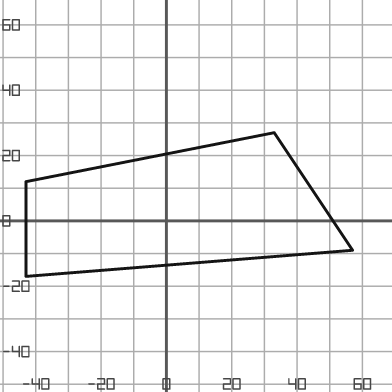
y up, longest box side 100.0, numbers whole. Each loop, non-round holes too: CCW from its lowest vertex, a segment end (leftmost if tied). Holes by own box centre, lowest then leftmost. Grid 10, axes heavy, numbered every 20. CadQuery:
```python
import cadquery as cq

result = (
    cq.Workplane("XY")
    .moveTo(-43.0, -17.0)
    .lineTo(57.0, -9.0)
    .lineTo(33.0, 27.0)
    .lineTo(-43.0, 12.0)
    .close()
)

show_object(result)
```